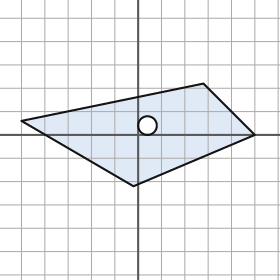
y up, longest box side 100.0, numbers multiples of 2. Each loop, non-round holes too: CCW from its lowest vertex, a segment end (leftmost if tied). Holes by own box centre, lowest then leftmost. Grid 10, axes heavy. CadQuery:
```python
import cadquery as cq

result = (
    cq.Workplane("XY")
    .moveTo(-2.0, -22.0)
    .lineTo(50.0, 0.0)
    .lineTo(28.0, 22.0)
    .lineTo(-50.0, 6.0)
    .close()
    .moveTo(4.0, 4.0)
    .circle(4.0)
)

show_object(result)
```